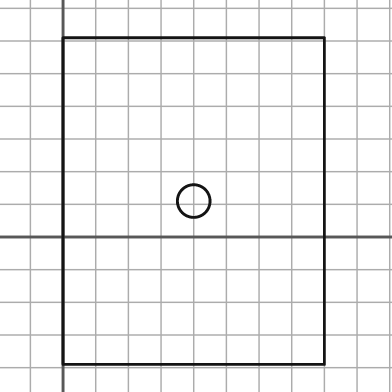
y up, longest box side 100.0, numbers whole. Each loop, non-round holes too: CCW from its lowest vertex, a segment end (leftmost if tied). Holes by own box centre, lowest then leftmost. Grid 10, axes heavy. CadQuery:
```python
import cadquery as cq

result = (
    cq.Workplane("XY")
    .moveTo(0.0, -39.0)
    .lineTo(80.0, -39.0)
    .lineTo(80.0, 61.0)
    .lineTo(0.0, 61.0)
    .close()
    .moveTo(40.0, 11.0)
    .circle(5.0)
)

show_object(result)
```